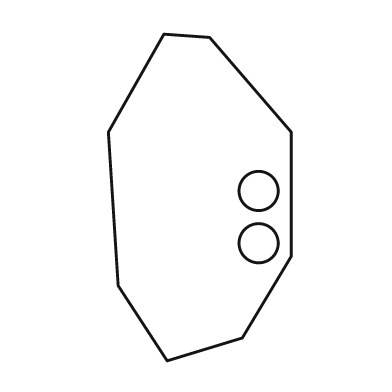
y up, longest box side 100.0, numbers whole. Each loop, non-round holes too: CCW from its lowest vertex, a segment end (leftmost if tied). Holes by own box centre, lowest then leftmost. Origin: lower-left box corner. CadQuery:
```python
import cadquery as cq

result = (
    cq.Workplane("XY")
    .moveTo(18.0, 0.0)
    .lineTo(41.0, 7.0)
    .lineTo(56.0, 32.0)
    .lineTo(56.0, 70.0)
    .lineTo(31.0, 99.0)
    .lineTo(17.0, 100.0)
    .lineTo(0.0, 70.0)
    .lineTo(3.0, 23.0)
    .close()
    .moveTo(46.0, 36.0)
    .circle(6.0)
    .moveTo(46.0, 52.0)
    .circle(6.0)
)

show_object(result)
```